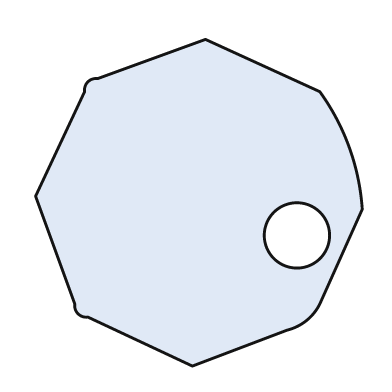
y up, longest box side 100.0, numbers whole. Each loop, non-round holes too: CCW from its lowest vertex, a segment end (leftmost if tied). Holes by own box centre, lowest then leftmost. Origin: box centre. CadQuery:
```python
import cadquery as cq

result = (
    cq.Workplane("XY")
    .moveTo(-2.0, -50.0)
    .lineTo(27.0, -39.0)
    .threePointArc((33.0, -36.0), (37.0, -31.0))
    .lineTo(50.0, -2.0)
    .threePointArc((46.0, 17.0), (37.0, 34.0))
    .lineTo(2.0, 50.0)
    .lineTo(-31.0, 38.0)
    .threePointArc((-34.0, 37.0), (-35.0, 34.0))
    .lineTo(-50.0, 2.0)
    .lineTo(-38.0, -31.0)
    .threePointArc((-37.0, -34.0), (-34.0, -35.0))
    .close()
    .moveTo(30.0, -10.0)
    .circle(10.0)
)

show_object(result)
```